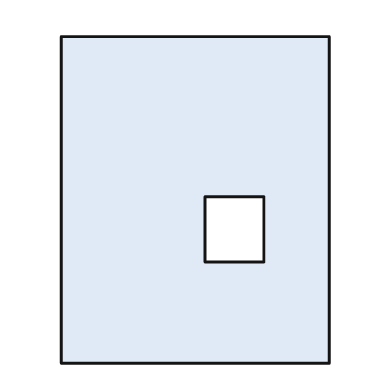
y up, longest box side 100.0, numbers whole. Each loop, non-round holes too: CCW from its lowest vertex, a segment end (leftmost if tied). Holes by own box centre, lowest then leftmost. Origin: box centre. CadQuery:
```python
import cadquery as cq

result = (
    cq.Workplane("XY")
    .moveTo(-41.0, -50.0)
    .lineTo(41.0, -50.0)
    .lineTo(41.0, 50.0)
    .lineTo(-41.0, 50.0)
    .close()
    .moveTo(3.0, -19.0)
    .lineTo(21.0, -19.0)
    .lineTo(21.0, 1.0)
    .lineTo(3.0, 1.0)
    .close()
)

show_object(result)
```